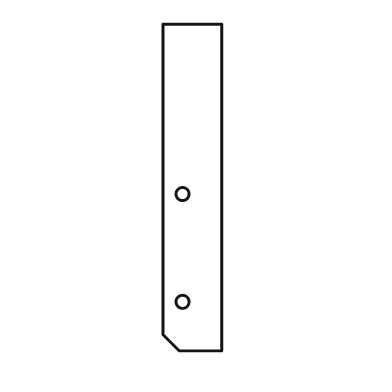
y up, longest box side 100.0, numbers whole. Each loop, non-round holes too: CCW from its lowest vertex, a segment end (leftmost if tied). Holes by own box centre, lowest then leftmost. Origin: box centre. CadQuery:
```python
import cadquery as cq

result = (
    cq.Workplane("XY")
    .moveTo(-4.0, -50.0)
    .lineTo(9.0, -50.0)
    .lineTo(9.0, 50.0)
    .lineTo(-9.0, 50.0)
    .lineTo(-9.0, -45.0)
    .close()
    .moveTo(-3.0, -35.0)
    .circle(2.0)
    .moveTo(-3.0, -2.0)
    .circle(2.0)
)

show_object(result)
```